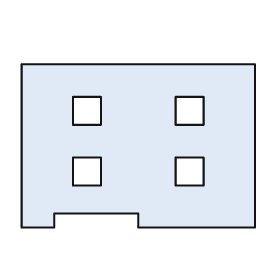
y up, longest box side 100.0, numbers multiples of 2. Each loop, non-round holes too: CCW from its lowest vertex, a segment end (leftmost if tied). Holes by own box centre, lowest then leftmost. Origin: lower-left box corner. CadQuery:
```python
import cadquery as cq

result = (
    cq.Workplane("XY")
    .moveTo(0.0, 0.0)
    .lineTo(14.0, 0.0)
    .lineTo(14.0, 6.0)
    .lineTo(50.0, 6.0)
    .lineTo(50.0, 0.0)
    .lineTo(100.0, 0.0)
    .lineTo(100.0, 70.0)
    .lineTo(0.0, 70.0)
    .close()
    .moveTo(22.0, 18.0)
    .lineTo(34.0, 18.0)
    .lineTo(34.0, 30.0)
    .lineTo(22.0, 30.0)
    .close()
    .moveTo(66.0, 18.0)
    .lineTo(78.0, 18.0)
    .lineTo(78.0, 30.0)
    .lineTo(66.0, 30.0)
    .close()
    .moveTo(22.0, 44.0)
    .lineTo(34.0, 44.0)
    .lineTo(34.0, 56.0)
    .lineTo(22.0, 56.0)
    .close()
    .moveTo(66.0, 44.0)
    .lineTo(78.0, 44.0)
    .lineTo(78.0, 56.0)
    .lineTo(66.0, 56.0)
    .close()
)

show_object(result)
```